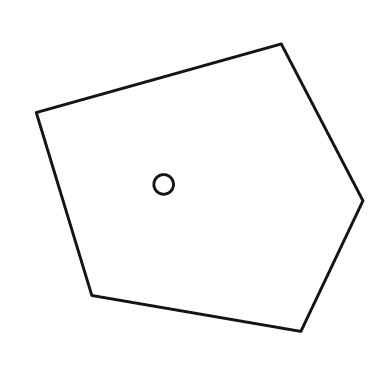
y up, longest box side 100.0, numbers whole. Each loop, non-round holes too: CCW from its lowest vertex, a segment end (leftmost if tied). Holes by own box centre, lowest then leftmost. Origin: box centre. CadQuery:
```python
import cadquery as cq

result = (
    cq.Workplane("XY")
    .moveTo(31.0, -44.0)
    .lineTo(50.0, -4.0)
    .lineTo(25.0, 44.0)
    .lineTo(-50.0, 23.0)
    .lineTo(-33.0, -33.0)
    .close()
    .moveTo(-11.0, 1.0)
    .circle(3.0)
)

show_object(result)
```